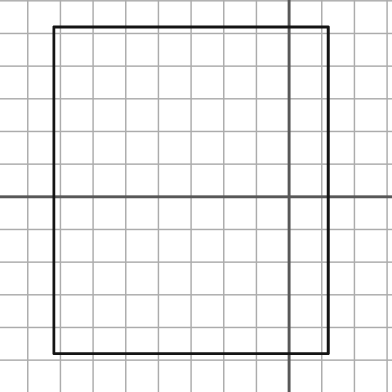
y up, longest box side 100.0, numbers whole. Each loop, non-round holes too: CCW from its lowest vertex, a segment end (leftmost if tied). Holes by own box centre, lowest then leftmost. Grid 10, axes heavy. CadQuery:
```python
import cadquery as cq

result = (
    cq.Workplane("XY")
    .moveTo(-72.0, -48.0)
    .lineTo(12.0, -48.0)
    .lineTo(12.0, 52.0)
    .lineTo(-72.0, 52.0)
    .close()
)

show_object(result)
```